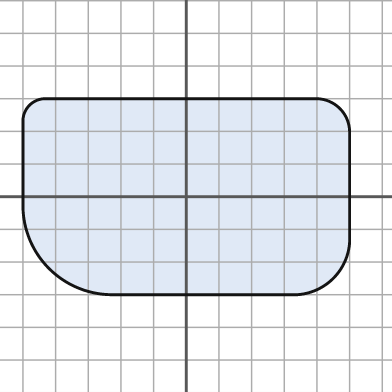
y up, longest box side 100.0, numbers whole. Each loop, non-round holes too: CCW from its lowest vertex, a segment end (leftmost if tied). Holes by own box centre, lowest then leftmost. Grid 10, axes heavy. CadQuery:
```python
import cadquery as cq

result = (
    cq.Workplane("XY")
    .moveTo(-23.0, -30.0)
    .lineTo(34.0, -30.0)
    .threePointArc((45.0, -25.0), (50.0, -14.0))
    .lineTo(50.0, 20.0)
    .threePointArc((47.0, 27.0), (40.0, 30.0))
    .lineTo(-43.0, 30.0)
    .threePointArc((-48.0, 28.0), (-50.0, 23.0))
    .lineTo(-50.0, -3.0)
    .threePointArc((-42.0, -22.0), (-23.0, -30.0))
    .close()
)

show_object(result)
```